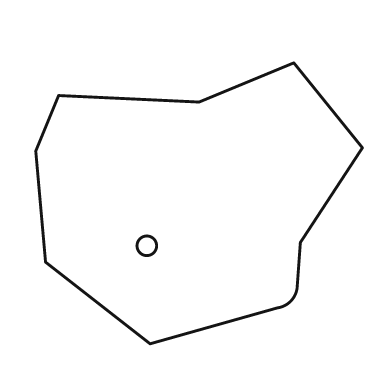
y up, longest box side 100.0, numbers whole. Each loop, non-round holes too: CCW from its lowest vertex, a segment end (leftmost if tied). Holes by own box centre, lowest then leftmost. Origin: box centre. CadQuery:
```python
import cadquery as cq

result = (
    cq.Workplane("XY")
    .moveTo(-15.0, -43.0)
    .lineTo(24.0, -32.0)
    .threePointArc((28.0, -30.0), (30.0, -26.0))
    .lineTo(31.0, -12.0)
    .lineTo(50.0, 17.0)
    .lineTo(29.0, 43.0)
    .lineTo(0.0, 31.0)
    .lineTo(-43.0, 33.0)
    .lineTo(-50.0, 16.0)
    .lineTo(-47.0, -18.0)
    .close()
    .moveTo(-16.0, -13.0)
    .circle(3.0)
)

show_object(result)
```